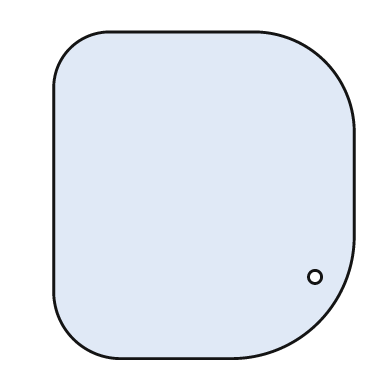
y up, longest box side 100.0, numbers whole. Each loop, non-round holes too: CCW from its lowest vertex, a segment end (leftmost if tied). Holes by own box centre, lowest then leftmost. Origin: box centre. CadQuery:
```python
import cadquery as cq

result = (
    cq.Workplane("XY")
    .moveTo(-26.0, -50.0)
    .lineTo(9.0, -50.0)
    .threePointArc((35.0, -39.0), (46.0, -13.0))
    .lineTo(46.0, 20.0)
    .threePointArc((37.0, 41.0), (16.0, 50.0))
    .lineTo(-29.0, 50.0)
    .threePointArc((-41.0, 45.0), (-46.0, 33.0))
    .lineTo(-46.0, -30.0)
    .threePointArc((-40.0, -44.0), (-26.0, -50.0))
    .close()
    .moveTo(34.0, -25.0)
    .circle(2.0)
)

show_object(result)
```